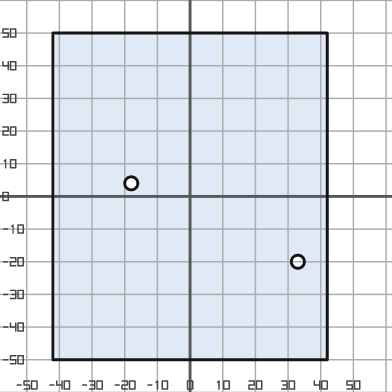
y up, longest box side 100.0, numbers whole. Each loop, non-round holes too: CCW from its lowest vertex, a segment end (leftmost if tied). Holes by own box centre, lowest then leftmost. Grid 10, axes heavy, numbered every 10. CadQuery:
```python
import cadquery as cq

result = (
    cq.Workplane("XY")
    .moveTo(-42.0, -50.0)
    .lineTo(42.0, -50.0)
    .lineTo(42.0, 50.0)
    .lineTo(-42.0, 50.0)
    .close()
    .moveTo(33.0, -20.0)
    .circle(2.0)
    .moveTo(-18.0, 4.0)
    .circle(2.0)
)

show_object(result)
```